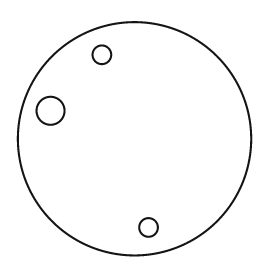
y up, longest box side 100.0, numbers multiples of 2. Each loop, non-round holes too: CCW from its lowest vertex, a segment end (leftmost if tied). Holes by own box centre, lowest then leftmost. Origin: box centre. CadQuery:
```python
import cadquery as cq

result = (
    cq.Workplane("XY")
    .moveTo(0.0, 0.0)
    .circle(50.0)
    .moveTo(6.0, -38.0)
    .circle(4.0)
    .moveTo(-36.0, 12.0)
    .circle(6.0)
    .moveTo(-14.0, 36.0)
    .circle(4.0)
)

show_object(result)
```